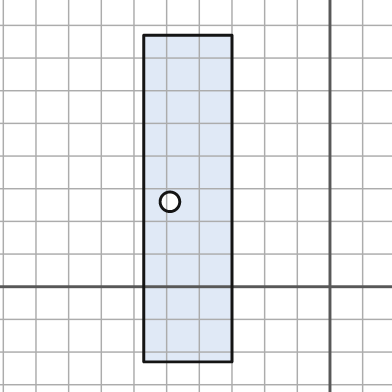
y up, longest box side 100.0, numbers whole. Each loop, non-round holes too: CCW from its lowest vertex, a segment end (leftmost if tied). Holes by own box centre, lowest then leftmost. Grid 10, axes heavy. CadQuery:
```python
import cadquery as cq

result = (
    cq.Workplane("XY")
    .moveTo(-57.0, -23.0)
    .lineTo(-30.0, -23.0)
    .lineTo(-30.0, 77.0)
    .lineTo(-57.0, 77.0)
    .close()
    .moveTo(-49.0, 26.0)
    .circle(3.0)
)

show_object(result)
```